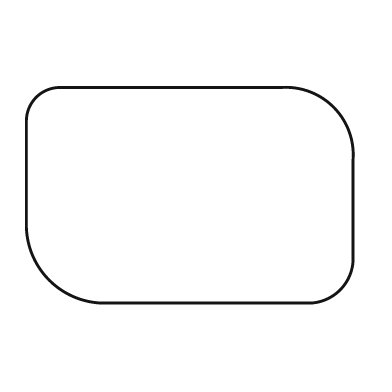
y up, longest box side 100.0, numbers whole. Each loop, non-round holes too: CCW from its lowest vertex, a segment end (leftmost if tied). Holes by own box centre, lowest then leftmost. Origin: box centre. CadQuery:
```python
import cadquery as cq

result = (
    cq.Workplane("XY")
    .moveTo(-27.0, -33.0)
    .lineTo(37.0, -33.0)
    .threePointArc((46.0, -29.0), (50.0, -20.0))
    .lineTo(50.0, 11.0)
    .threePointArc((44.0, 27.0), (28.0, 33.0))
    .lineTo(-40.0, 33.0)
    .threePointArc((-47.0, 30.0), (-50.0, 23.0))
    .lineTo(-50.0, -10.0)
    .threePointArc((-43.0, -26.0), (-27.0, -33.0))
    .close()
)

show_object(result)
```